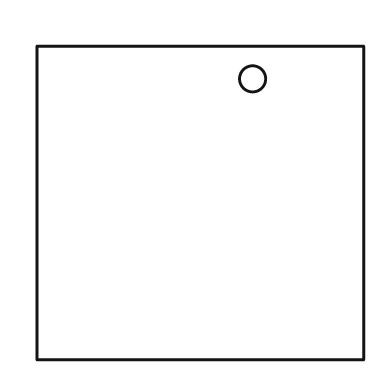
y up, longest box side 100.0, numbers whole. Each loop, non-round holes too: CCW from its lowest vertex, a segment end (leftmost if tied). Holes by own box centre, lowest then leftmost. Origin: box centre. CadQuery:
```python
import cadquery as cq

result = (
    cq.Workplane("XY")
    .moveTo(-50.0, -48.0)
    .lineTo(50.0, -48.0)
    .lineTo(50.0, 48.0)
    .lineTo(-50.0, 48.0)
    .close()
    .moveTo(16.0, 38.0)
    .circle(4.0)
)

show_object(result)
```